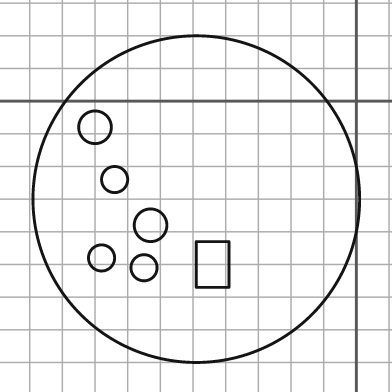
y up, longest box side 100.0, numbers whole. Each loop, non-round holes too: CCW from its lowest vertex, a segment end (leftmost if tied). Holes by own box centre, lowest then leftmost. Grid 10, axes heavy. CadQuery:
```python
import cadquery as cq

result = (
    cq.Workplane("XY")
    .moveTo(-49.0, -30.0)
    .circle(50.0)
    .moveTo(-65.0, -51.0)
    .circle(4.0)
    .moveTo(-49.0, -57.0)
    .lineTo(-39.0, -57.0)
    .lineTo(-39.0, -43.0)
    .lineTo(-49.0, -43.0)
    .close()
    .moveTo(-78.0, -48.0)
    .circle(4.0)
    .moveTo(-63.0, -38.0)
    .circle(5.0)
    .moveTo(-74.0, -24.0)
    .circle(4.0)
    .moveTo(-80.0, -8.0)
    .circle(5.0)
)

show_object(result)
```